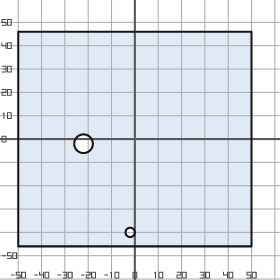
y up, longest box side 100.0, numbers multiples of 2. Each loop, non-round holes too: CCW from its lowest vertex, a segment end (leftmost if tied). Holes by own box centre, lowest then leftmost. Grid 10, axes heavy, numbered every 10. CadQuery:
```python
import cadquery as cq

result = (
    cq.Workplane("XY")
    .moveTo(-50.0, -46.0)
    .lineTo(50.0, -46.0)
    .lineTo(50.0, 46.0)
    .lineTo(-50.0, 46.0)
    .close()
    .moveTo(-2.0, -40.0)
    .circle(2.0)
    .moveTo(-22.0, -2.0)
    .circle(4.0)
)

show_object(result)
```